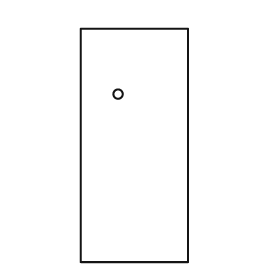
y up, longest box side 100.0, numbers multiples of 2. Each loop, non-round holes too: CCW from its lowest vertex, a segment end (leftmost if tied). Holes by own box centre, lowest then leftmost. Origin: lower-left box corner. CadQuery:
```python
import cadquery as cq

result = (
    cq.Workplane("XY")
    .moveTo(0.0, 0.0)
    .lineTo(46.0, 0.0)
    .lineTo(46.0, 100.0)
    .lineTo(0.0, 100.0)
    .close()
    .moveTo(16.0, 72.0)
    .circle(2.0)
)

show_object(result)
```